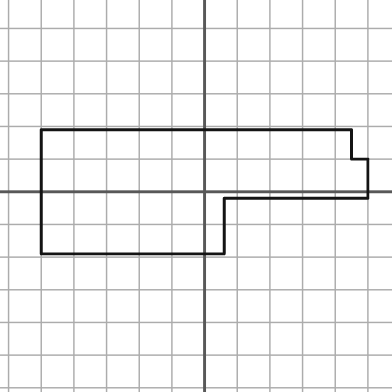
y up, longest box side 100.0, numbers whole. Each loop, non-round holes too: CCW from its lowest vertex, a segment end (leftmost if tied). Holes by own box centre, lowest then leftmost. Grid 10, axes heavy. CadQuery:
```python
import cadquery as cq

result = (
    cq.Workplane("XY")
    .moveTo(-50.0, -19.0)
    .lineTo(6.0, -19.0)
    .lineTo(6.0, -2.0)
    .lineTo(50.0, -2.0)
    .lineTo(50.0, 10.0)
    .lineTo(45.0, 10.0)
    .lineTo(45.0, 19.0)
    .lineTo(-50.0, 19.0)
    .close()
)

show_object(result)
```